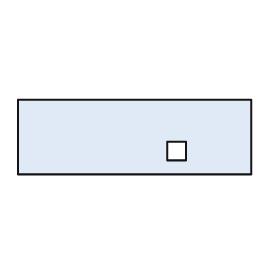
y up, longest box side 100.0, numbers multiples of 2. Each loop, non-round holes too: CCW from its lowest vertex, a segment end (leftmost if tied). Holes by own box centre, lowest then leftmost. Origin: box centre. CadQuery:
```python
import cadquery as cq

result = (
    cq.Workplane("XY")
    .moveTo(-50.0, -16.0)
    .lineTo(50.0, -16.0)
    .lineTo(50.0, 16.0)
    .lineTo(-50.0, 16.0)
    .close()
    .moveTo(14.0, -10.0)
    .lineTo(22.0, -10.0)
    .lineTo(22.0, -2.0)
    .lineTo(14.0, -2.0)
    .close()
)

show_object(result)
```